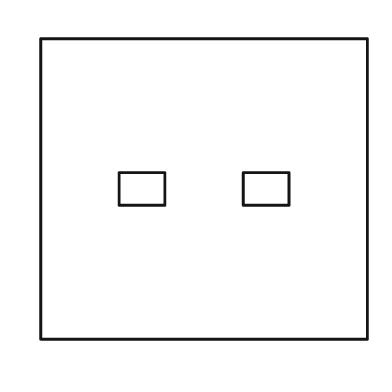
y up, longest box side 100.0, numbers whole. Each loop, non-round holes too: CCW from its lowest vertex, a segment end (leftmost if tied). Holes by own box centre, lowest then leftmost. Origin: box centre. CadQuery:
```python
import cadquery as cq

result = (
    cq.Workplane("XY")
    .moveTo(-50.0, -46.0)
    .lineTo(50.0, -46.0)
    .lineTo(50.0, 46.0)
    .lineTo(-50.0, 46.0)
    .close()
    .moveTo(-26.0, -5.0)
    .lineTo(-12.0, -5.0)
    .lineTo(-12.0, 5.0)
    .lineTo(-26.0, 5.0)
    .close()
    .moveTo(12.0, -5.0)
    .lineTo(26.0, -5.0)
    .lineTo(26.0, 5.0)
    .lineTo(12.0, 5.0)
    .close()
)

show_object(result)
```